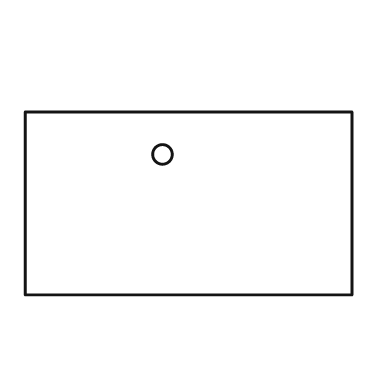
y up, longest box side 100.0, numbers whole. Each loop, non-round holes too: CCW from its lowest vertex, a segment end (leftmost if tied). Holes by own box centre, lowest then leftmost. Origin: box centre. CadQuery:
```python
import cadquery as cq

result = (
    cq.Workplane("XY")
    .moveTo(-50.0, -28.0)
    .lineTo(50.0, -28.0)
    .lineTo(50.0, 28.0)
    .lineTo(-50.0, 28.0)
    .close()
    .moveTo(-8.0, 15.0)
    .circle(3.0)
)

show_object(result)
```